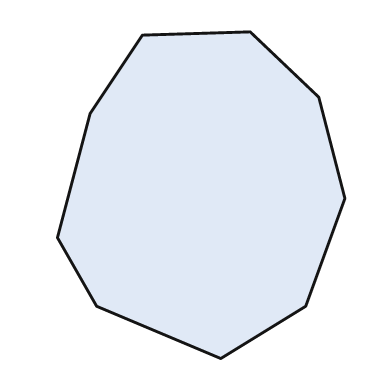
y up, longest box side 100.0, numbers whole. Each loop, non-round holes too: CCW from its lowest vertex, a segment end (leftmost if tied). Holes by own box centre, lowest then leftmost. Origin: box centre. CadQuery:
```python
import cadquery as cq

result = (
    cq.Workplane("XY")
    .moveTo(6.0, -50.0)
    .lineTo(32.0, -34.0)
    .lineTo(44.0, -1.0)
    .lineTo(36.0, 30.0)
    .lineTo(15.0, 50.0)
    .lineTo(-18.0, 49.0)
    .lineTo(-34.0, 25.0)
    .lineTo(-44.0, -13.0)
    .lineTo(-32.0, -34.0)
    .close()
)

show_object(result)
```